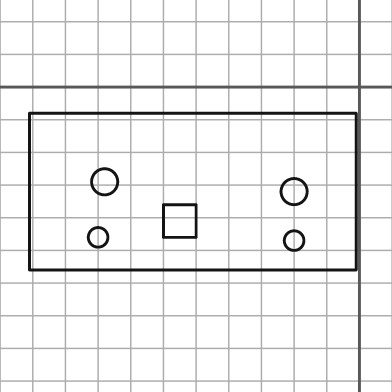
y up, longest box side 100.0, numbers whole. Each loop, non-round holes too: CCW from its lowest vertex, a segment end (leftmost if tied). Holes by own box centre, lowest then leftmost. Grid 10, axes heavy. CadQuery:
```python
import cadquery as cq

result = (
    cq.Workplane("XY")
    .moveTo(-101.0, -56.0)
    .lineTo(-1.0, -56.0)
    .lineTo(-1.0, -8.0)
    .lineTo(-101.0, -8.0)
    .close()
    .moveTo(-20.0, -47.0)
    .circle(3.0)
    .moveTo(-80.0, -46.0)
    .circle(3.0)
    .moveTo(-60.0, -46.0)
    .lineTo(-50.0, -46.0)
    .lineTo(-50.0, -36.0)
    .lineTo(-60.0, -36.0)
    .close()
    .moveTo(-20.0, -32.0)
    .circle(4.0)
    .moveTo(-78.0, -29.0)
    .circle(4.0)
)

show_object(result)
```